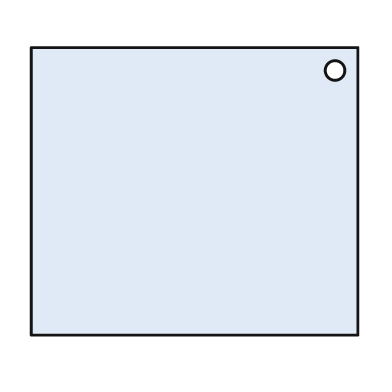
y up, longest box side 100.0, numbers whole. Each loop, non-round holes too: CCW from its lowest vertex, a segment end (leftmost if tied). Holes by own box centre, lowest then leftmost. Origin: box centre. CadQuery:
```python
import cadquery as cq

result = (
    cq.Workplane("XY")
    .moveTo(-50.0, -44.0)
    .lineTo(50.0, -44.0)
    .lineTo(50.0, 44.0)
    .lineTo(-50.0, 44.0)
    .close()
    .moveTo(43.0, 37.0)
    .circle(3.0)
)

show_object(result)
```